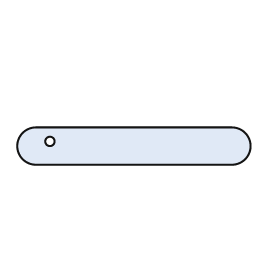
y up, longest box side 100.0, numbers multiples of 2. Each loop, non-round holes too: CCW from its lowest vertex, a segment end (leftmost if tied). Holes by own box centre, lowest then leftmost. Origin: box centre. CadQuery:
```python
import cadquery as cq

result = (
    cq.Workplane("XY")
    .moveTo(-42.0, -8.0)
    .lineTo(42.0, -8.0)
    .threePointArc((50.0, 0.0), (42.0, 8.0))
    .lineTo(-42.0, 8.0)
    .threePointArc((-50.0, 0.0), (-42.0, -8.0))
    .close()
    .moveTo(-36.0, 2.0)
    .circle(2.0)
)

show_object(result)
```